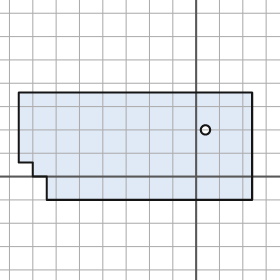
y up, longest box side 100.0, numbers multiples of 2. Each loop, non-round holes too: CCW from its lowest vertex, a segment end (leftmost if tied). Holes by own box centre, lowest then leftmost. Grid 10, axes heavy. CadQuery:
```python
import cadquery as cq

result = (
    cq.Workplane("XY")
    .moveTo(-64.0, -10.0)
    .lineTo(24.0, -10.0)
    .lineTo(24.0, 36.0)
    .lineTo(-76.0, 36.0)
    .lineTo(-76.0, 6.0)
    .lineTo(-70.0, 6.0)
    .lineTo(-70.0, 0.0)
    .lineTo(-64.0, 0.0)
    .close()
    .moveTo(4.0, 20.0)
    .circle(2.0)
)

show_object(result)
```